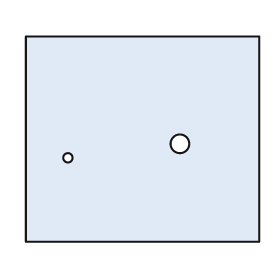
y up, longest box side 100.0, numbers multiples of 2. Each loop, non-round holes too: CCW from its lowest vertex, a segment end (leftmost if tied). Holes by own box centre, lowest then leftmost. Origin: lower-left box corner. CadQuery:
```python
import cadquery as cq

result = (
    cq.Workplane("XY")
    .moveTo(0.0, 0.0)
    .lineTo(100.0, 0.0)
    .lineTo(100.0, 88.0)
    .lineTo(0.0, 88.0)
    .close()
    .moveTo(18.0, 36.0)
    .circle(2.0)
    .moveTo(66.0, 42.0)
    .circle(4.0)
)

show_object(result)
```